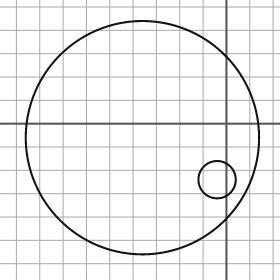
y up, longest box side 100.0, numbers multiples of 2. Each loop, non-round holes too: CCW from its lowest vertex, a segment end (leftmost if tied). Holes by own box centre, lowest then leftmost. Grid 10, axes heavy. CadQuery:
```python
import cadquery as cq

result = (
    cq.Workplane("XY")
    .moveTo(-36.0, -6.0)
    .circle(50.0)
    .moveTo(-4.0, -24.0)
    .circle(8.0)
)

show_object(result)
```